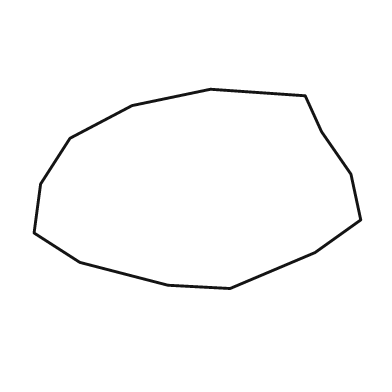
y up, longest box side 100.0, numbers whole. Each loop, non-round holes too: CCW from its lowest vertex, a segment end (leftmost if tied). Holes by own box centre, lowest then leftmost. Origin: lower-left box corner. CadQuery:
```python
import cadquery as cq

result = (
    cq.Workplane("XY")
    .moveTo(60.0, 0.0)
    .lineTo(86.0, 11.0)
    .lineTo(100.0, 21.0)
    .lineTo(97.0, 35.0)
    .lineTo(88.0, 48.0)
    .lineTo(83.0, 59.0)
    .lineTo(54.0, 61.0)
    .lineTo(30.0, 56.0)
    .lineTo(11.0, 46.0)
    .lineTo(2.0, 32.0)
    .lineTo(0.0, 17.0)
    .lineTo(14.0, 8.0)
    .lineTo(41.0, 1.0)
    .close()
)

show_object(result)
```